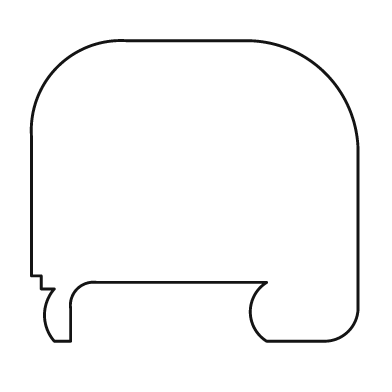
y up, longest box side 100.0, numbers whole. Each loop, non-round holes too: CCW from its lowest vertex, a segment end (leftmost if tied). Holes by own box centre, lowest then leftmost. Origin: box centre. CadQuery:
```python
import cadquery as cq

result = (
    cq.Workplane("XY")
    .moveTo(-43.0, -46.0)
    .lineTo(-38.0, -46.0)
    .lineTo(-38.0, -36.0)
    .threePointArc((-36.0, -30.0), (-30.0, -28.0))
    .lineTo(22.0, -28.0)
    .threePointArc((17.0, -37.0), (22.0, -46.0))
    .lineTo(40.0, -46.0)
    .threePointArc((47.0, -43.0), (50.0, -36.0))
    .lineTo(50.0, 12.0)
    .threePointArc((40.0, 36.0), (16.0, 46.0))
    .lineTo(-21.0, 46.0)
    .threePointArc((-42.0, 38.0), (-50.0, 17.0))
    .lineTo(-50.0, -26.0)
    .lineTo(-47.0, -26.0)
    .lineTo(-47.0, -30.0)
    .lineTo(-43.0, -30.0)
    .threePointArc((-46.0, -38.0), (-43.0, -46.0))
    .close()
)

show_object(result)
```